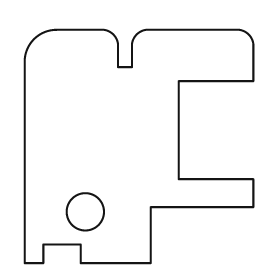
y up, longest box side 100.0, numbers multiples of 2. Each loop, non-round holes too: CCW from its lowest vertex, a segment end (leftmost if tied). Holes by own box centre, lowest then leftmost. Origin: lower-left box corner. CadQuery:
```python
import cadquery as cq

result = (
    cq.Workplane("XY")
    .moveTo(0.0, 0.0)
    .lineTo(8.0, 0.0)
    .lineTo(8.0, 8.0)
    .lineTo(24.0, 8.0)
    .lineTo(24.0, 0.0)
    .lineTo(54.0, 0.0)
    .lineTo(54.0, 24.0)
    .lineTo(98.0, 24.0)
    .lineTo(98.0, 36.0)
    .lineTo(66.0, 36.0)
    .lineTo(66.0, 78.0)
    .lineTo(98.0, 78.0)
    .lineTo(98.0, 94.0)
    .threePointArc((96.0, 98.0), (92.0, 100.0))
    .lineTo(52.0, 100.0)
    .threePointArc((48.0, 98.0), (46.0, 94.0))
    .lineTo(46.0, 84.0)
    .lineTo(40.0, 84.0)
    .lineTo(40.0, 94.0)
    .threePointArc((38.0, 98.0), (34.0, 100.0))
    .lineTo(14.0, 100.0)
    .threePointArc((4.0, 96.0), (0.0, 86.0))
    .close()
    .moveTo(26.0, 22.0)
    .circle(8.0)
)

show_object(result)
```